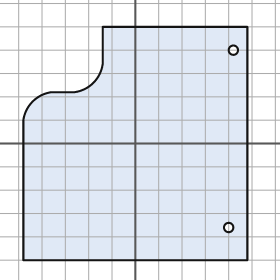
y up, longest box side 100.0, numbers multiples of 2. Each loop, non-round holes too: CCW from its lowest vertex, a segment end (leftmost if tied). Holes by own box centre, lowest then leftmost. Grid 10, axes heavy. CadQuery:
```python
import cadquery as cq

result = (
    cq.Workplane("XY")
    .moveTo(-48.0, -50.0)
    .lineTo(48.0, -50.0)
    .lineTo(48.0, 50.0)
    .lineTo(-14.0, 50.0)
    .lineTo(-14.0, 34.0)
    .threePointArc((-18.0, 26.0), (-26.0, 22.0))
    .lineTo(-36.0, 22.0)
    .threePointArc((-44.0, 18.0), (-48.0, 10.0))
    .close()
    .moveTo(40.0, -36.0)
    .circle(2.0)
    .moveTo(42.0, 40.0)
    .circle(2.0)
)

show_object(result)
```